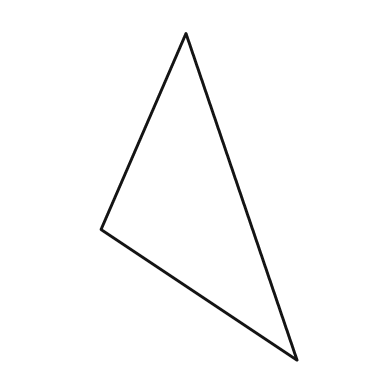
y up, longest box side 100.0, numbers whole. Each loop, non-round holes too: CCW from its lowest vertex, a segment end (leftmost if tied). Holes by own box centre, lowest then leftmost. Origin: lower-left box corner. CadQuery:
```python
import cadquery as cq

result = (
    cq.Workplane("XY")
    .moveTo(60.0, 0.0)
    .lineTo(26.0, 100.0)
    .lineTo(0.0, 40.0)
    .close()
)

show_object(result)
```